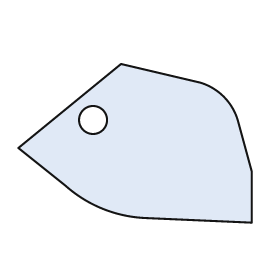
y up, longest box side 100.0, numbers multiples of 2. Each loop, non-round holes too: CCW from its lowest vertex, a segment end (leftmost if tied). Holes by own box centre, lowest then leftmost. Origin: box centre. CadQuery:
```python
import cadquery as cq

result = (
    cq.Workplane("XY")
    .moveTo(50.0, -34.0)
    .lineTo(50.0, -12.0)
    .lineTo(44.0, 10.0)
    .threePointArc((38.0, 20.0), (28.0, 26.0))
    .lineTo(-6.0, 34.0)
    .lineTo(-50.0, -2.0)
    .lineTo(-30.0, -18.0)
    .threePointArc((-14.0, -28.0), (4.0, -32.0))
    .close()
    .moveTo(-18.0, 10.0)
    .circle(6.0)
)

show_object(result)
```